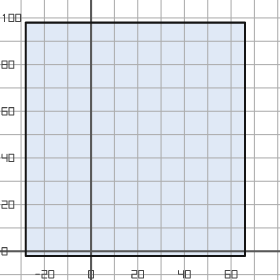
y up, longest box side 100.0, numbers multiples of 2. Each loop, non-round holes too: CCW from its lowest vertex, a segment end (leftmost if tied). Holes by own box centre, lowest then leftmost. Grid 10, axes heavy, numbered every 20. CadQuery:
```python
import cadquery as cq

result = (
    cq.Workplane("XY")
    .moveTo(-28.0, -2.0)
    .lineTo(66.0, -2.0)
    .lineTo(66.0, 98.0)
    .lineTo(-28.0, 98.0)
    .close()
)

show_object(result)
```